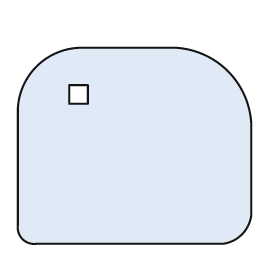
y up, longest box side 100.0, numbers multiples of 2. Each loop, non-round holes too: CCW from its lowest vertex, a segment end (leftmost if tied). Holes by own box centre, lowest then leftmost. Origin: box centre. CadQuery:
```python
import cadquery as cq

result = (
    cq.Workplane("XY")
    .moveTo(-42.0, -42.0)
    .lineTo(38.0, -42.0)
    .threePointArc((46.0, -38.0), (50.0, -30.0))
    .lineTo(50.0, 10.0)
    .threePointArc((40.0, 32.0), (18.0, 42.0))
    .lineTo(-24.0, 42.0)
    .threePointArc((-42.0, 34.0), (-50.0, 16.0))
    .lineTo(-50.0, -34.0)
    .threePointArc((-48.0, -40.0), (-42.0, -42.0))
    .close()
    .moveTo(-28.0, 18.0)
    .lineTo(-20.0, 18.0)
    .lineTo(-20.0, 26.0)
    .lineTo(-28.0, 26.0)
    .close()
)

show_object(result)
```